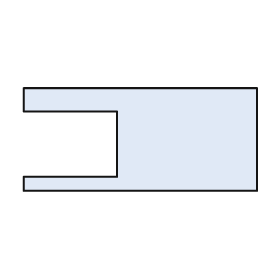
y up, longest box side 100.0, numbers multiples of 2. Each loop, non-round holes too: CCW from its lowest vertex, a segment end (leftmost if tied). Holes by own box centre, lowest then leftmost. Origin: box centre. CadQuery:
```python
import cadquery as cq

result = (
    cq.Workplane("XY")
    .moveTo(-50.0, -22.0)
    .lineTo(50.0, -22.0)
    .lineTo(50.0, 22.0)
    .lineTo(-50.0, 22.0)
    .lineTo(-50.0, 12.0)
    .lineTo(-10.0, 12.0)
    .lineTo(-10.0, -16.0)
    .lineTo(-50.0, -16.0)
    .close()
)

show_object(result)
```